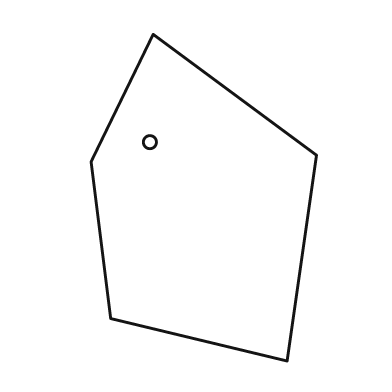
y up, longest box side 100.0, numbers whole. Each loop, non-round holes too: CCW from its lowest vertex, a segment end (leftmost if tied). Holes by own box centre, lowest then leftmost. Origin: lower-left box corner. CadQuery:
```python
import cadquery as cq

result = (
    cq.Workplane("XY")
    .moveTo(60.0, 0.0)
    .lineTo(69.0, 63.0)
    .lineTo(19.0, 100.0)
    .lineTo(0.0, 61.0)
    .lineTo(6.0, 13.0)
    .close()
    .moveTo(18.0, 67.0)
    .circle(2.0)
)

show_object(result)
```